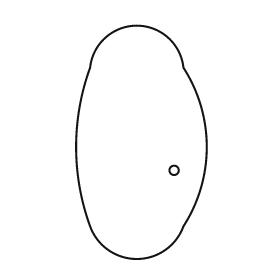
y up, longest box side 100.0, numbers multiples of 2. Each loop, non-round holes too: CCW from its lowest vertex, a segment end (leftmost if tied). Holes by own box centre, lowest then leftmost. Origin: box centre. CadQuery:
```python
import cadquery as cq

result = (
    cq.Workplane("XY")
    .moveTo(-22.0, -36.0)
    .threePointArc((-2.0, -50.0), (18.0, -36.0))
    .threePointArc((28.0, -2.0), (18.0, 32.0))
    .threePointArc((-2.0, 50.0), (-22.0, 32.0))
    .threePointArc((-28.0, -2.0), (-22.0, -36.0))
    .close()
    .moveTo(14.0, -12.0)
    .circle(2.0)
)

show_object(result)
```